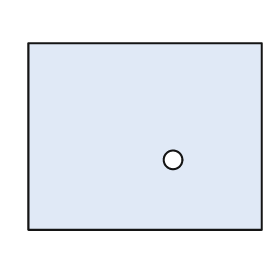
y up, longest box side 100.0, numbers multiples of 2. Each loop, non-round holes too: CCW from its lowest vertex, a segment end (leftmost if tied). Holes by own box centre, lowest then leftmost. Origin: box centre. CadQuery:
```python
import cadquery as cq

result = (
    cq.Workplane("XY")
    .moveTo(-50.0, -40.0)
    .lineTo(50.0, -40.0)
    .lineTo(50.0, 40.0)
    .lineTo(-50.0, 40.0)
    .close()
    .moveTo(12.0, -10.0)
    .circle(4.0)
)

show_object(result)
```